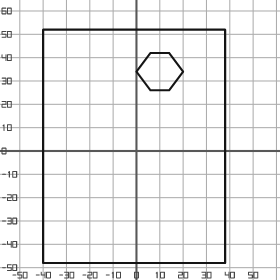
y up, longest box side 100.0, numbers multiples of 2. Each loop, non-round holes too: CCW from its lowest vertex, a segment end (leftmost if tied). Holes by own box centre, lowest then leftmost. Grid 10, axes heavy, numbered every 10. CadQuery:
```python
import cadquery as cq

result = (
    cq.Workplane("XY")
    .moveTo(-40.0, -48.0)
    .lineTo(38.0, -48.0)
    .lineTo(38.0, 52.0)
    .lineTo(-40.0, 52.0)
    .close()
    .moveTo(6.0, 26.0)
    .lineTo(14.0, 26.0)
    .lineTo(20.0, 34.0)
    .lineTo(14.0, 42.0)
    .lineTo(6.0, 42.0)
    .lineTo(0.0, 34.0)
    .close()
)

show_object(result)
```